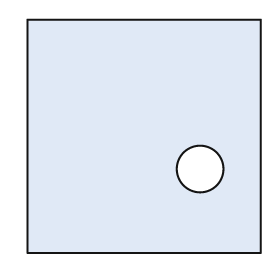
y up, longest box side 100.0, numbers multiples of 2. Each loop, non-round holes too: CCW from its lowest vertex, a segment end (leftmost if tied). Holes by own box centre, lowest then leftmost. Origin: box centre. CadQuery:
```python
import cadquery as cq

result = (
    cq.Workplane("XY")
    .moveTo(-50.0, -50.0)
    .lineTo(50.0, -50.0)
    .lineTo(50.0, 50.0)
    .lineTo(-50.0, 50.0)
    .close()
    .moveTo(24.0, -14.0)
    .circle(10.0)
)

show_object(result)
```